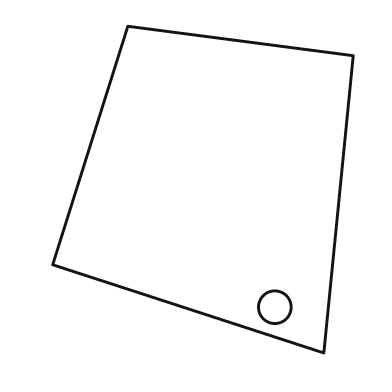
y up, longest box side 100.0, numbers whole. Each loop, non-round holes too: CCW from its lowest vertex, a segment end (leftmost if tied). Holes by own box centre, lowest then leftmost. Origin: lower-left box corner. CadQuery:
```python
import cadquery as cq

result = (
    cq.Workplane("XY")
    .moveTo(83.0, 0.0)
    .lineTo(92.0, 91.0)
    .lineTo(23.0, 100.0)
    .lineTo(0.0, 27.0)
    .close()
    .moveTo(68.0, 14.0)
    .circle(5.0)
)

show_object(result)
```